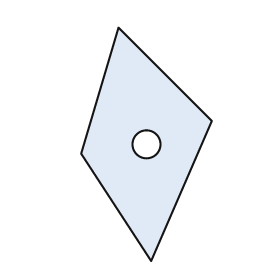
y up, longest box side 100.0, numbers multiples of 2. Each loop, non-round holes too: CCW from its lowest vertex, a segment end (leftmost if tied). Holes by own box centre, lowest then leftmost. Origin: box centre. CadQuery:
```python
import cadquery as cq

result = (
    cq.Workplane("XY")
    .moveTo(2.0, -50.0)
    .lineTo(28.0, 10.0)
    .lineTo(-12.0, 50.0)
    .lineTo(-28.0, -4.0)
    .close()
    .moveTo(0.0, 0.0)
    .circle(6.0)
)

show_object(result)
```